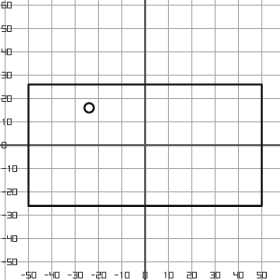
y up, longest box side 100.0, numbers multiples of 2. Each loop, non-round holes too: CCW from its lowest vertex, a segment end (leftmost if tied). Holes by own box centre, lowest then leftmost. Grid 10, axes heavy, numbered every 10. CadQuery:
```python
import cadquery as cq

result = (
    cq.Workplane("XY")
    .moveTo(-50.0, -26.0)
    .lineTo(50.0, -26.0)
    .lineTo(50.0, 26.0)
    .lineTo(-50.0, 26.0)
    .close()
    .moveTo(-24.0, 16.0)
    .circle(2.0)
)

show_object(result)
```